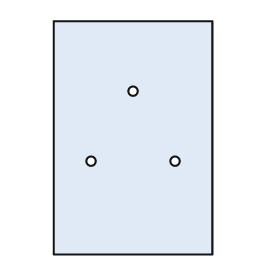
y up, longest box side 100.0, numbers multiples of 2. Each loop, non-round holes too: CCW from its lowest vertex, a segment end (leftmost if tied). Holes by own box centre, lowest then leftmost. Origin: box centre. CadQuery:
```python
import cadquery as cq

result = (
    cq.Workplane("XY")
    .moveTo(-34.0, -50.0)
    .lineTo(34.0, -50.0)
    .lineTo(34.0, 50.0)
    .lineTo(-34.0, 50.0)
    .close()
    .moveTo(-18.0, -10.0)
    .circle(2.0)
    .moveTo(18.0, -10.0)
    .circle(2.0)
    .moveTo(0.0, 20.0)
    .circle(2.0)
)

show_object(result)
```